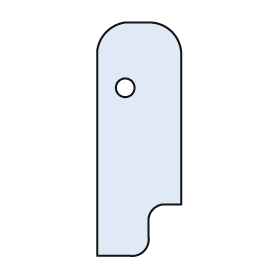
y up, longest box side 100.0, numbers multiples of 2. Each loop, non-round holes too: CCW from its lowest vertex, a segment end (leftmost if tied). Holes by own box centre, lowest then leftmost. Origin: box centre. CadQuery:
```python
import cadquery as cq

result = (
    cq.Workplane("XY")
    .moveTo(-18.0, -50.0)
    .lineTo(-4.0, -50.0)
    .threePointArc((2.0, -48.0), (4.0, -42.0))
    .lineTo(4.0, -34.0)
    .threePointArc((6.0, -30.0), (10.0, -28.0))
    .lineTo(18.0, -28.0)
    .lineTo(18.0, 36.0)
    .threePointArc((14.0, 46.0), (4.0, 50.0))
    .lineTo(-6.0, 50.0)
    .threePointArc((-14.0, 46.0), (-18.0, 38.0))
    .close()
    .moveTo(-6.0, 22.0)
    .circle(4.0)
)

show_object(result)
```